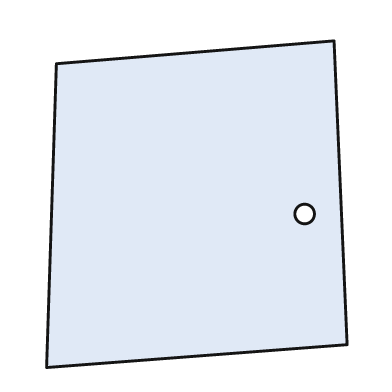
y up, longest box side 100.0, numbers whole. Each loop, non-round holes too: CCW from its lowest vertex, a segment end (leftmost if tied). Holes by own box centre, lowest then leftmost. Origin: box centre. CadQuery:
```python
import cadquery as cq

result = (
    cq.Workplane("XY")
    .moveTo(-46.0, -50.0)
    .lineTo(46.0, -43.0)
    .lineTo(42.0, 50.0)
    .lineTo(-43.0, 43.0)
    .close()
    .moveTo(33.0, -3.0)
    .circle(3.0)
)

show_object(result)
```